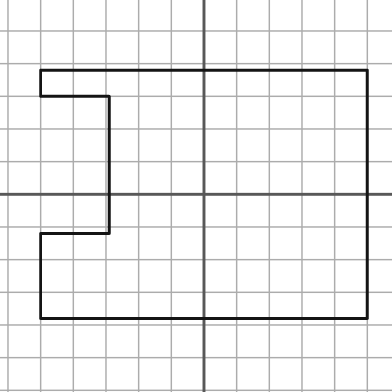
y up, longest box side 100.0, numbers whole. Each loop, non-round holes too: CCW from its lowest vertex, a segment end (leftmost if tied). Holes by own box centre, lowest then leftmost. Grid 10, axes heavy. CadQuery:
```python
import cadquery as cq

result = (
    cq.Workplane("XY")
    .moveTo(-50.0, -38.0)
    .lineTo(50.0, -38.0)
    .lineTo(50.0, 38.0)
    .lineTo(-50.0, 38.0)
    .lineTo(-50.0, 30.0)
    .lineTo(-29.0, 30.0)
    .lineTo(-29.0, -12.0)
    .lineTo(-50.0, -12.0)
    .close()
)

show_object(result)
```